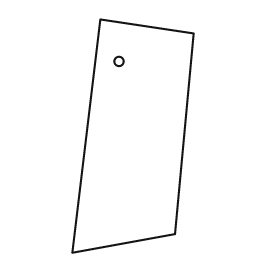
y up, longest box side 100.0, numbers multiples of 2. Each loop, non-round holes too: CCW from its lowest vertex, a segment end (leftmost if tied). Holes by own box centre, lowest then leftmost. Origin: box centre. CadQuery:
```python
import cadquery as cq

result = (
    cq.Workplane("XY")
    .moveTo(-26.0, -50.0)
    .lineTo(18.0, -42.0)
    .lineTo(26.0, 44.0)
    .lineTo(-14.0, 50.0)
    .close()
    .moveTo(-6.0, 32.0)
    .circle(2.0)
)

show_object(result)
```